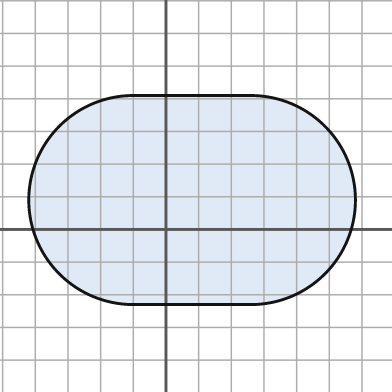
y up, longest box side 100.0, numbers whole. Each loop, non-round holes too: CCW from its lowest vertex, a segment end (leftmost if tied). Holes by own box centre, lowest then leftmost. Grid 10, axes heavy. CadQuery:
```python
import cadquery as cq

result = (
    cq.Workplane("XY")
    .moveTo(-10.0, -23.0)
    .lineTo(26.0, -23.0)
    .threePointArc((58.0, 9.0), (26.0, 41.0))
    .lineTo(-10.0, 41.0)
    .threePointArc((-42.0, 9.0), (-10.0, -23.0))
    .close()
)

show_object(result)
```